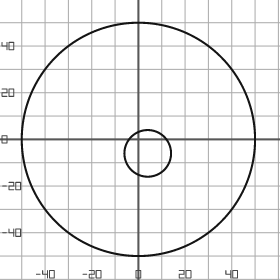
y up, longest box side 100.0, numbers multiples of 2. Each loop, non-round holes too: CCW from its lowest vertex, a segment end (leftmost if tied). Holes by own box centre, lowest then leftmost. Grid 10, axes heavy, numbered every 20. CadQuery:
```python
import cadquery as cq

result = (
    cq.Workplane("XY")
    .moveTo(0.0, 0.0)
    .circle(50.0)
    .moveTo(4.0, -6.0)
    .circle(10.0)
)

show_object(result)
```